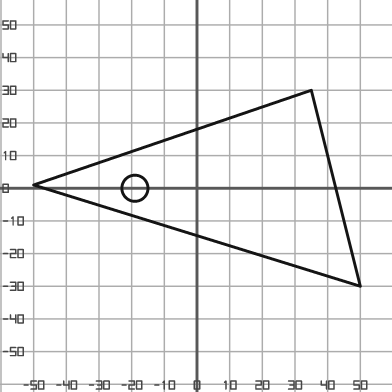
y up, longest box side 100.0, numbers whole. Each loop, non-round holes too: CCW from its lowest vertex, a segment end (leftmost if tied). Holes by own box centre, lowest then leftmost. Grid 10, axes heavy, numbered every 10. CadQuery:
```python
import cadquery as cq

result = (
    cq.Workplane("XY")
    .moveTo(50.0, -30.0)
    .lineTo(35.0, 30.0)
    .lineTo(-50.0, 1.0)
    .close()
    .moveTo(-19.0, 0.0)
    .circle(4.0)
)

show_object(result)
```